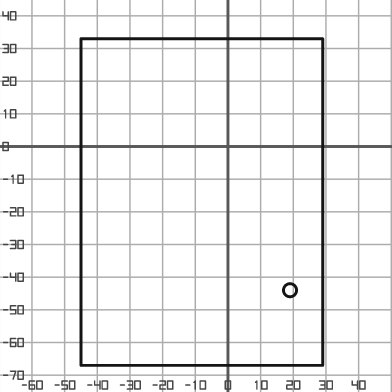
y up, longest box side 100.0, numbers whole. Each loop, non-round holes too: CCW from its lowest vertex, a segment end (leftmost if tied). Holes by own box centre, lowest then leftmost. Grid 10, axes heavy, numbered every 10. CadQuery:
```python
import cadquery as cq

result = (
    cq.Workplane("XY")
    .moveTo(-45.0, -67.0)
    .lineTo(29.0, -67.0)
    .lineTo(29.0, 33.0)
    .lineTo(-45.0, 33.0)
    .close()
    .moveTo(19.0, -44.0)
    .circle(2.0)
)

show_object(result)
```